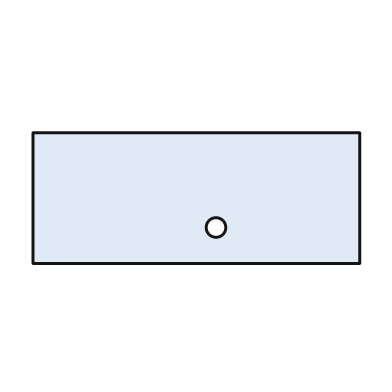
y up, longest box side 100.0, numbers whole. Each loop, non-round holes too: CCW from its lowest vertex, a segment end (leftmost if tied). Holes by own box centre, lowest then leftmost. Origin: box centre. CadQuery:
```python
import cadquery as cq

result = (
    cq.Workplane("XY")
    .moveTo(-50.0, -20.0)
    .lineTo(50.0, -20.0)
    .lineTo(50.0, 20.0)
    .lineTo(-50.0, 20.0)
    .close()
    .moveTo(6.0, -9.0)
    .circle(3.0)
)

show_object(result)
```